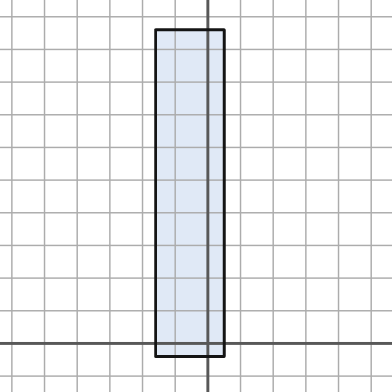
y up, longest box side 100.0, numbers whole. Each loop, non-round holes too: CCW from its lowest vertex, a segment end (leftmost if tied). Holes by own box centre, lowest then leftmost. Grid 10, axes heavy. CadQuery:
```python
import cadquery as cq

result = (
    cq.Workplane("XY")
    .moveTo(-16.0, -4.0)
    .lineTo(5.0, -4.0)
    .lineTo(5.0, 96.0)
    .lineTo(-16.0, 96.0)
    .close()
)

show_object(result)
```